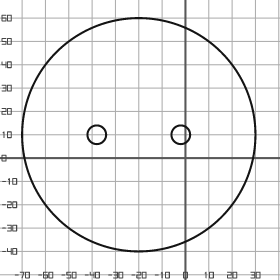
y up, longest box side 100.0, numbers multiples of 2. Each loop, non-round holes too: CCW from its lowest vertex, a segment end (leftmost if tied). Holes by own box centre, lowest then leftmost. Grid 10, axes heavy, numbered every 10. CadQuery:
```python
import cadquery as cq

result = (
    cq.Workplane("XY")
    .moveTo(-20.0, 10.0)
    .circle(50.0)
    .moveTo(-38.0, 10.0)
    .circle(4.0)
    .moveTo(-2.0, 10.0)
    .circle(4.0)
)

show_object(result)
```